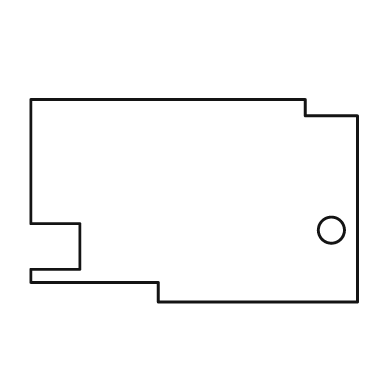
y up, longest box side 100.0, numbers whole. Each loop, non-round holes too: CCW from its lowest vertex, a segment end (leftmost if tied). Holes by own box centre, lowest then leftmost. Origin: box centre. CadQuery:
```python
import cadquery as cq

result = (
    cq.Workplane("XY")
    .moveTo(-11.0, -31.0)
    .lineTo(50.0, -31.0)
    .lineTo(50.0, 26.0)
    .lineTo(34.0, 26.0)
    .lineTo(34.0, 31.0)
    .lineTo(-50.0, 31.0)
    .lineTo(-50.0, -7.0)
    .lineTo(-35.0, -7.0)
    .lineTo(-35.0, -21.0)
    .lineTo(-50.0, -21.0)
    .lineTo(-50.0, -25.0)
    .lineTo(-11.0, -25.0)
    .close()
    .moveTo(42.0, -9.0)
    .circle(4.0)
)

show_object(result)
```